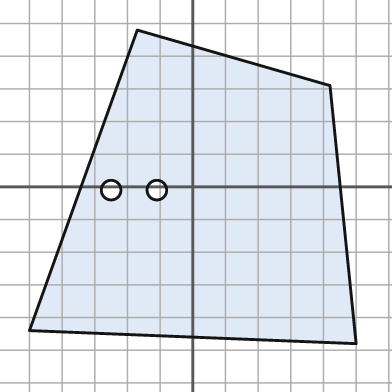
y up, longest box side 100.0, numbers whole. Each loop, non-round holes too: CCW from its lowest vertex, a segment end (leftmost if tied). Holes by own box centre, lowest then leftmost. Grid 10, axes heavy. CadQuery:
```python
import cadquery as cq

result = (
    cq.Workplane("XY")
    .moveTo(50.0, -48.0)
    .lineTo(42.0, 31.0)
    .lineTo(-17.0, 48.0)
    .lineTo(-50.0, -44.0)
    .close()
    .moveTo(-25.0, -1.0)
    .circle(3.0)
    .moveTo(-11.0, -1.0)
    .circle(3.0)
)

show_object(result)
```